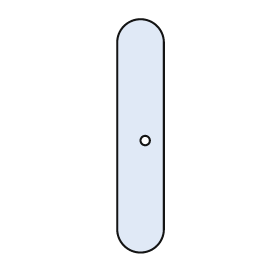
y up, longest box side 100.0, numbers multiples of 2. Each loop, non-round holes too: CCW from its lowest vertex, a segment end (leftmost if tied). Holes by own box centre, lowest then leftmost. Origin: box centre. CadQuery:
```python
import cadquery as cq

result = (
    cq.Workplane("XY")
    .moveTo(-10.0, -40.0)
    .threePointArc((0.0, -50.0), (10.0, -40.0))
    .lineTo(10.0, 40.0)
    .threePointArc((0.0, 50.0), (-10.0, 40.0))
    .close()
    .moveTo(2.0, -2.0)
    .circle(2.0)
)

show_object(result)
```